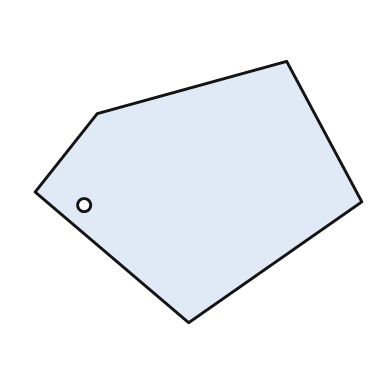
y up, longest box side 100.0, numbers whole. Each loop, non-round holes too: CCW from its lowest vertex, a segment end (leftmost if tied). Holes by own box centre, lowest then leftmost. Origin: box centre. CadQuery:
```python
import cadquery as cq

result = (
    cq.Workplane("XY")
    .moveTo(-3.0, -40.0)
    .lineTo(50.0, -3.0)
    .lineTo(27.0, 40.0)
    .lineTo(-31.0, 24.0)
    .lineTo(-50.0, 0.0)
    .close()
    .moveTo(-35.0, -4.0)
    .circle(2.0)
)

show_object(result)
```